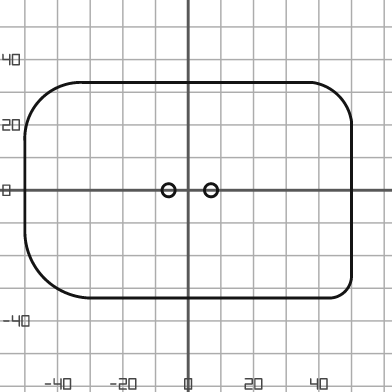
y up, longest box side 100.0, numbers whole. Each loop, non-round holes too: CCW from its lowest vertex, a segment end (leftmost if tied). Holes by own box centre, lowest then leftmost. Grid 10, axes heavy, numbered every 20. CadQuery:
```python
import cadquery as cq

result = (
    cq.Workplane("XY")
    .moveTo(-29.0, -33.0)
    .lineTo(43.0, -33.0)
    .threePointArc((48.0, -31.0), (50.0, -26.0))
    .lineTo(50.0, 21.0)
    .threePointArc((46.0, 29.0), (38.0, 33.0))
    .lineTo(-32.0, 33.0)
    .threePointArc((-45.0, 28.0), (-50.0, 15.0))
    .lineTo(-50.0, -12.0)
    .threePointArc((-44.0, -27.0), (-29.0, -33.0))
    .close()
    .moveTo(-6.0, 0.0)
    .circle(2.0)
    .moveTo(7.0, 0.0)
    .circle(2.0)
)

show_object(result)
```